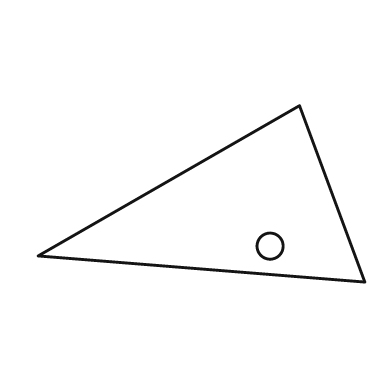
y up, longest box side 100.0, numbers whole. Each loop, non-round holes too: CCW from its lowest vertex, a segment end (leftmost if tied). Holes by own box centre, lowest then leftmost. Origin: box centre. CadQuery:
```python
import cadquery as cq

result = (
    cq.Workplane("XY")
    .moveTo(50.0, -27.0)
    .lineTo(30.0, 27.0)
    .lineTo(-50.0, -19.0)
    .close()
    .moveTo(21.0, -16.0)
    .circle(4.0)
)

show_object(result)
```